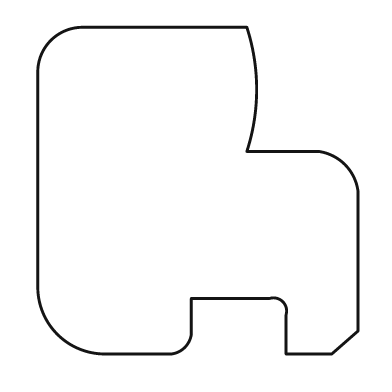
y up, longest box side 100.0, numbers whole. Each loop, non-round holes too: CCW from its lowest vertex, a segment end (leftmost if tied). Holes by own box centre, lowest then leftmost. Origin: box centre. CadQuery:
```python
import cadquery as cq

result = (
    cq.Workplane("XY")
    .moveTo(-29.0, -50.0)
    .lineTo(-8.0, -50.0)
    .threePointArc((-4.0, -48.0), (-2.0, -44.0))
    .lineTo(-2.0, -33.0)
    .lineTo(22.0, -33.0)
    .threePointArc((26.0, -34.0), (27.0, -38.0))
    .lineTo(27.0, -50.0)
    .lineTo(41.0, -50.0)
    .lineTo(49.0, -43.0)
    .lineTo(49.0, 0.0)
    .threePointArc((45.0, 8.0), (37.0, 12.0))
    .lineTo(15.0, 12.0)
    .threePointArc((18.0, 31.0), (15.0, 50.0))
    .lineTo(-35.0, 50.0)
    .threePointArc((-45.0, 46.0), (-49.0, 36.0))
    .lineTo(-49.0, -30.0)
    .threePointArc((-43.0, -44.0), (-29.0, -50.0))
    .close()
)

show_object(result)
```